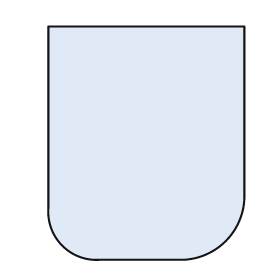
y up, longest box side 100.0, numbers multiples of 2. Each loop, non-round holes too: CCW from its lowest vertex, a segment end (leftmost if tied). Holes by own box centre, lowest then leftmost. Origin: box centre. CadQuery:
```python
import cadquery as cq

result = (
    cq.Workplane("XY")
    .moveTo(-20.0, -50.0)
    .lineTo(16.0, -50.0)
    .threePointArc((34.0, -42.0), (42.0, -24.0))
    .lineTo(42.0, 50.0)
    .lineTo(-42.0, 50.0)
    .lineTo(-42.0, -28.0)
    .threePointArc((-36.0, -44.0), (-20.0, -50.0))
    .close()
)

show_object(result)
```